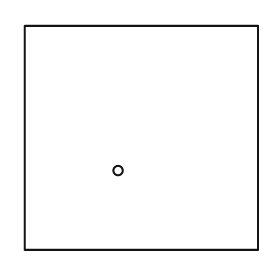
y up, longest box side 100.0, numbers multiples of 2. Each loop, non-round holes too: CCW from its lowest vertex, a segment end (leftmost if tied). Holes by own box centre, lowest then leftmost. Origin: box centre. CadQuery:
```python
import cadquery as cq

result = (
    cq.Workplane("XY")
    .moveTo(-50.0, -48.0)
    .lineTo(50.0, -48.0)
    .lineTo(50.0, 48.0)
    .lineTo(-50.0, 48.0)
    .close()
    .moveTo(-10.0, -14.0)
    .circle(2.0)
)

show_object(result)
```